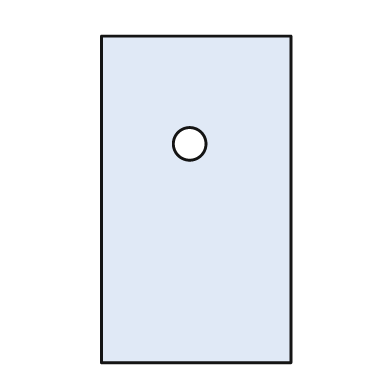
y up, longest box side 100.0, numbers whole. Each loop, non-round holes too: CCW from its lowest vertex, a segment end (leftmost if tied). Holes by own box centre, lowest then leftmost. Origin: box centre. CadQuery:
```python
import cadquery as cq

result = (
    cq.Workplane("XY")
    .moveTo(-29.0, -50.0)
    .lineTo(29.0, -50.0)
    .lineTo(29.0, 50.0)
    .lineTo(-29.0, 50.0)
    .close()
    .moveTo(-2.0, 17.0)
    .circle(5.0)
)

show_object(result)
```